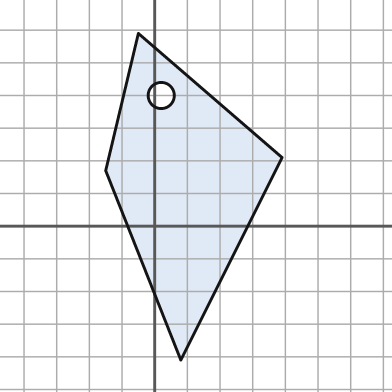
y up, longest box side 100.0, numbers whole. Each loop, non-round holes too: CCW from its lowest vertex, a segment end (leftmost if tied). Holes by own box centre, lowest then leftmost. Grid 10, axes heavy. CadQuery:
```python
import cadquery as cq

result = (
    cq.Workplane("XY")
    .moveTo(8.0, -41.0)
    .lineTo(39.0, 21.0)
    .lineTo(-5.0, 59.0)
    .lineTo(-15.0, 17.0)
    .close()
    .moveTo(2.0, 40.0)
    .circle(4.0)
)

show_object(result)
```